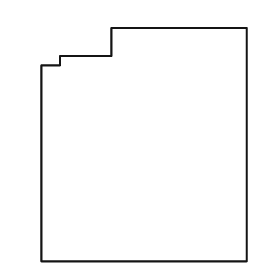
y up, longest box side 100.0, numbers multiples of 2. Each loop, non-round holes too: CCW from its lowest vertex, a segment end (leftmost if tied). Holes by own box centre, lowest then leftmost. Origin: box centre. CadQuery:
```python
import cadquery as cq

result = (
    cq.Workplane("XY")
    .moveTo(-44.0, -50.0)
    .lineTo(44.0, -50.0)
    .lineTo(44.0, 50.0)
    .lineTo(-14.0, 50.0)
    .lineTo(-14.0, 38.0)
    .lineTo(-36.0, 38.0)
    .lineTo(-36.0, 34.0)
    .lineTo(-44.0, 34.0)
    .close()
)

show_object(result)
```